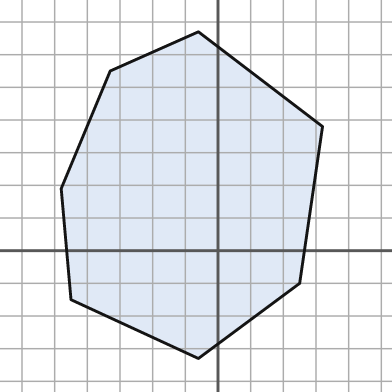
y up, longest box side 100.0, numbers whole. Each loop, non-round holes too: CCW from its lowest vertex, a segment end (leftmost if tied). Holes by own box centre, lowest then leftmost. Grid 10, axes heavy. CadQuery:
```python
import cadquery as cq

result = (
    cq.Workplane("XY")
    .moveTo(-6.0, -33.0)
    .lineTo(25.0, -10.0)
    .lineTo(32.0, 38.0)
    .lineTo(-6.0, 67.0)
    .lineTo(-33.0, 55.0)
    .lineTo(-48.0, 19.0)
    .lineTo(-45.0, -15.0)
    .close()
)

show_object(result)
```